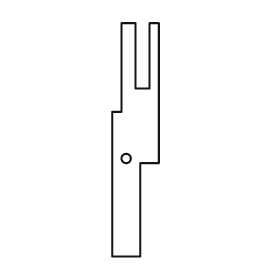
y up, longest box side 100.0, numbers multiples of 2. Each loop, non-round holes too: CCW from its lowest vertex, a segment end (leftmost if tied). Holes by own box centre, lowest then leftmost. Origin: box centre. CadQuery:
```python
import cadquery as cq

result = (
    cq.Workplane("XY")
    .moveTo(-10.0, -50.0)
    .lineTo(2.0, -50.0)
    .lineTo(2.0, -10.0)
    .lineTo(10.0, -10.0)
    .lineTo(10.0, 50.0)
    .lineTo(6.0, 50.0)
    .lineTo(6.0, 22.0)
    .lineTo(0.0, 22.0)
    .lineTo(0.0, 50.0)
    .lineTo(-6.0, 50.0)
    .lineTo(-6.0, 12.0)
    .lineTo(-10.0, 12.0)
    .close()
    .moveTo(-4.0, -8.0)
    .circle(2.0)
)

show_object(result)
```